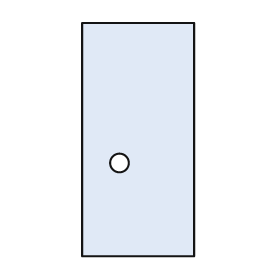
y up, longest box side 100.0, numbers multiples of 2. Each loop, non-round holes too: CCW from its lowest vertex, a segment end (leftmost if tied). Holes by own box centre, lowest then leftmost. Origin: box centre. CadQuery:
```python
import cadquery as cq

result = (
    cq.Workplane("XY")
    .moveTo(-24.0, -50.0)
    .lineTo(24.0, -50.0)
    .lineTo(24.0, 50.0)
    .lineTo(-24.0, 50.0)
    .close()
    .moveTo(-8.0, -10.0)
    .circle(4.0)
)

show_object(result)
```